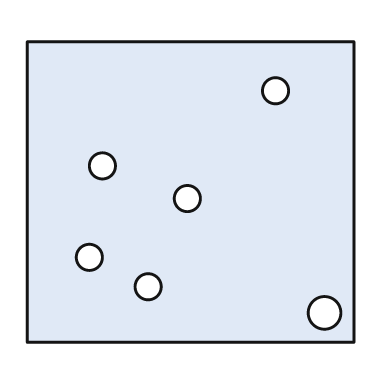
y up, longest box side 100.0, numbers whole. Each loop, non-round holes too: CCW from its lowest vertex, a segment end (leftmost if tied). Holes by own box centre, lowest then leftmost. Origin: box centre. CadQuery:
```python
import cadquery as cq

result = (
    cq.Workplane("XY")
    .moveTo(-50.0, -46.0)
    .lineTo(50.0, -46.0)
    .lineTo(50.0, 46.0)
    .lineTo(-50.0, 46.0)
    .close()
    .moveTo(41.0, -37.0)
    .circle(5.0)
    .moveTo(-13.0, -29.0)
    .circle(4.0)
    .moveTo(-31.0, -20.0)
    .circle(4.0)
    .moveTo(-1.0, -2.0)
    .circle(4.0)
    .moveTo(-27.0, 8.0)
    .circle(4.0)
    .moveTo(26.0, 31.0)
    .circle(4.0)
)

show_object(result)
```